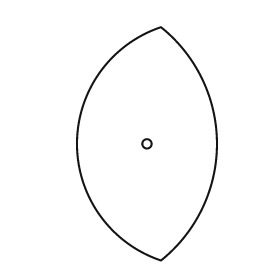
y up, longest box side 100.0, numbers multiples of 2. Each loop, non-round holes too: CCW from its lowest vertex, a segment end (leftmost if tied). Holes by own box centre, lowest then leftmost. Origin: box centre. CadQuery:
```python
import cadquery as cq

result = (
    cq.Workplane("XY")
    .moveTo(6.0, -50.0)
    .threePointArc((30.0, 0.0), (6.0, 50.0))
    .threePointArc((-30.0, 0.0), (6.0, -50.0))
    .close()
    .moveTo(0.0, 0.0)
    .circle(2.0)
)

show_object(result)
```